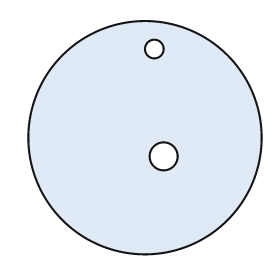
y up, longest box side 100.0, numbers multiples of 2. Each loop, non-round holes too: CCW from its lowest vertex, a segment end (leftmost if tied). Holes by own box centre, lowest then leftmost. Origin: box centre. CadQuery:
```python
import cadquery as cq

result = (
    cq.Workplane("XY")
    .moveTo(0.0, 0.0)
    .circle(50.0)
    .moveTo(8.0, -8.0)
    .circle(6.0)
    .moveTo(4.0, 38.0)
    .circle(4.0)
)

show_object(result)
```